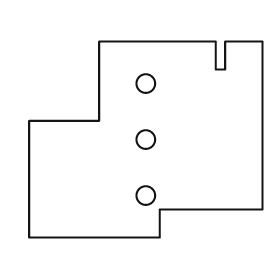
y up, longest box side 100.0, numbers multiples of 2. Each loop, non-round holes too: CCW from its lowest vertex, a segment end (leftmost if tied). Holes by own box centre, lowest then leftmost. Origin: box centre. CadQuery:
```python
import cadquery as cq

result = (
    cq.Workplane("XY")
    .moveTo(-50.0, -42.0)
    .lineTo(6.0, -42.0)
    .lineTo(6.0, -30.0)
    .lineTo(50.0, -30.0)
    .lineTo(50.0, 42.0)
    .lineTo(34.0, 42.0)
    .lineTo(34.0, 30.0)
    .lineTo(30.0, 30.0)
    .lineTo(30.0, 42.0)
    .lineTo(-20.0, 42.0)
    .lineTo(-20.0, 8.0)
    .lineTo(-50.0, 8.0)
    .close()
    .moveTo(0.0, -24.0)
    .circle(4.0)
    .moveTo(0.0, 0.0)
    .circle(4.0)
    .moveTo(0.0, 24.0)
    .circle(4.0)
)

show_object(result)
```